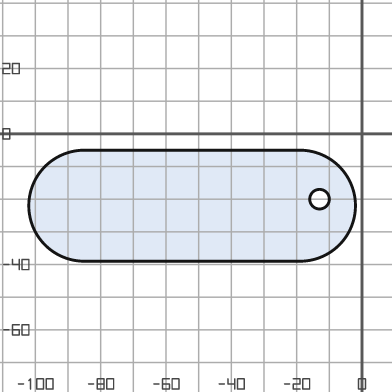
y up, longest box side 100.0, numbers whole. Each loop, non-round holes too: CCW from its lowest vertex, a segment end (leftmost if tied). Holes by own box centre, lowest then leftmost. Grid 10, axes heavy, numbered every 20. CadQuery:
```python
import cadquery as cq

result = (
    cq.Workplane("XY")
    .moveTo(-85.0, -39.0)
    .lineTo(-19.0, -39.0)
    .threePointArc((-2.0, -22.0), (-19.0, -5.0))
    .lineTo(-85.0, -5.0)
    .threePointArc((-102.0, -22.0), (-85.0, -39.0))
    .close()
    .moveTo(-13.0, -20.0)
    .circle(3.0)
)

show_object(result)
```